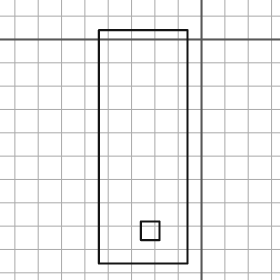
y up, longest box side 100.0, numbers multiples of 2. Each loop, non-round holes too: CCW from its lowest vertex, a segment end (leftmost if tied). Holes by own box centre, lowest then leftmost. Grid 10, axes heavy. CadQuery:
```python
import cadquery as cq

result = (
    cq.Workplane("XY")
    .moveTo(-44.0, -96.0)
    .lineTo(-6.0, -96.0)
    .lineTo(-6.0, 4.0)
    .lineTo(-44.0, 4.0)
    .close()
    .moveTo(-26.0, -86.0)
    .lineTo(-18.0, -86.0)
    .lineTo(-18.0, -78.0)
    .lineTo(-26.0, -78.0)
    .close()
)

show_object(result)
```